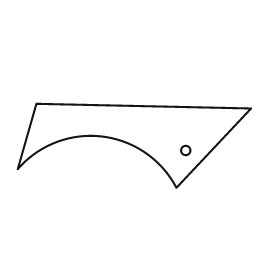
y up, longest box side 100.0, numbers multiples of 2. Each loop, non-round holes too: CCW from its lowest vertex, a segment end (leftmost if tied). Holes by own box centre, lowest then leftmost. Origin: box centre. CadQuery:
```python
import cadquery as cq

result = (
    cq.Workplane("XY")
    .moveTo(18.0, -18.0)
    .lineTo(50.0, 16.0)
    .lineTo(-42.0, 18.0)
    .lineTo(-50.0, -10.0)
    .threePointArc((-14.0, 4.0), (18.0, -18.0))
    .close()
    .moveTo(22.0, -2.0)
    .circle(2.0)
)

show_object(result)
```